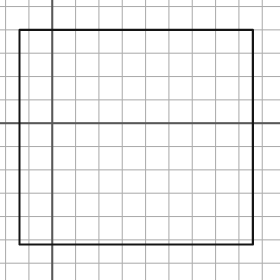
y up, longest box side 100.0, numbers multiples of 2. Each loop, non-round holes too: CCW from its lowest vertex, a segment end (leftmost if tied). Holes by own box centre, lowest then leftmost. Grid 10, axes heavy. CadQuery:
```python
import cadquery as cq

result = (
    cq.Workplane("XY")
    .moveTo(-14.0, -52.0)
    .lineTo(86.0, -52.0)
    .lineTo(86.0, 40.0)
    .lineTo(-14.0, 40.0)
    .close()
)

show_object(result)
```